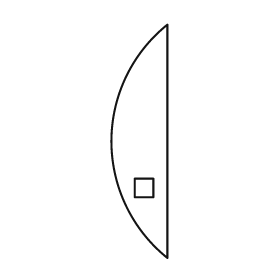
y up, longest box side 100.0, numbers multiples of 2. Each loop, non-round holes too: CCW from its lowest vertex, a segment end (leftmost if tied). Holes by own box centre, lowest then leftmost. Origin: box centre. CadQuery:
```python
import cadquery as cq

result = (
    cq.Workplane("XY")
    .moveTo(12.0, -50.0)
    .lineTo(12.0, 50.0)
    .threePointArc((-12.0, 0.0), (12.0, -50.0))
    .close()
    .moveTo(-2.0, -24.0)
    .lineTo(6.0, -24.0)
    .lineTo(6.0, -16.0)
    .lineTo(-2.0, -16.0)
    .close()
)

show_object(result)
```